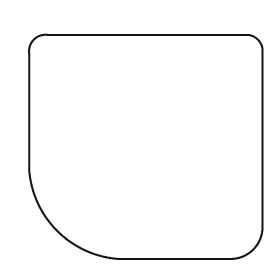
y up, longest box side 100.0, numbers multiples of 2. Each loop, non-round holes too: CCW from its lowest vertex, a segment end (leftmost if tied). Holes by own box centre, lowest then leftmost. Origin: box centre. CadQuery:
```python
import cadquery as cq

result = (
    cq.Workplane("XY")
    .moveTo(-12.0, -48.0)
    .lineTo(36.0, -48.0)
    .threePointArc((46.0, -44.0), (50.0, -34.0))
    .lineTo(50.0, 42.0)
    .threePointArc((48.0, 46.0), (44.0, 48.0))
    .lineTo(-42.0, 48.0)
    .threePointArc((-48.0, 46.0), (-50.0, 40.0))
    .lineTo(-50.0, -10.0)
    .threePointArc((-38.0, -36.0), (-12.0, -48.0))
    .close()
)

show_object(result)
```